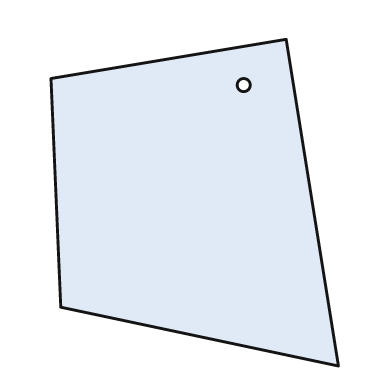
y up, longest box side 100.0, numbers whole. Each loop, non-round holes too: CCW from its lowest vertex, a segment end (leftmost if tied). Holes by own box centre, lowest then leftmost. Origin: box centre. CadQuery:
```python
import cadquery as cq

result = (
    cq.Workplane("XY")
    .moveTo(44.0, -50.0)
    .lineTo(28.0, 50.0)
    .lineTo(-44.0, 38.0)
    .lineTo(-41.0, -32.0)
    .close()
    .moveTo(15.0, 36.0)
    .circle(2.0)
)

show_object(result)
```